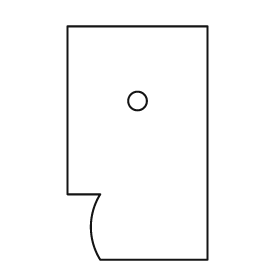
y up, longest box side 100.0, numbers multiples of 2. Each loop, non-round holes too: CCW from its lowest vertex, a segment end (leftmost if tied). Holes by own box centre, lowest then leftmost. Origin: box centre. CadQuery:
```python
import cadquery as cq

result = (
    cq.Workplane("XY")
    .moveTo(-16.0, -50.0)
    .lineTo(30.0, -50.0)
    .lineTo(30.0, 50.0)
    .lineTo(-30.0, 50.0)
    .lineTo(-30.0, -22.0)
    .lineTo(-16.0, -22.0)
    .threePointArc((-20.0, -36.0), (-16.0, -50.0))
    .close()
    .moveTo(0.0, 18.0)
    .circle(4.0)
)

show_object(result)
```